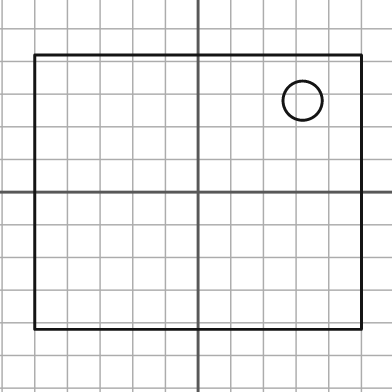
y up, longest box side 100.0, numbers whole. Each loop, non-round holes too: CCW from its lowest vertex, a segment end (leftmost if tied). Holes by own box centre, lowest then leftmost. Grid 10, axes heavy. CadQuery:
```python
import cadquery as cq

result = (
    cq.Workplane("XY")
    .moveTo(-50.0, -42.0)
    .lineTo(50.0, -42.0)
    .lineTo(50.0, 42.0)
    .lineTo(-50.0, 42.0)
    .close()
    .moveTo(32.0, 28.0)
    .circle(6.0)
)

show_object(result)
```